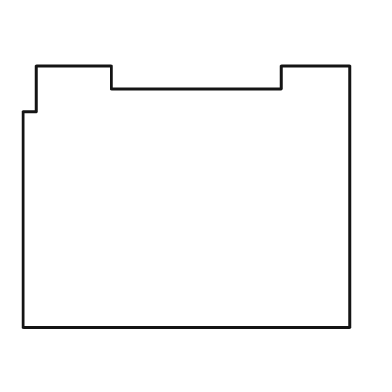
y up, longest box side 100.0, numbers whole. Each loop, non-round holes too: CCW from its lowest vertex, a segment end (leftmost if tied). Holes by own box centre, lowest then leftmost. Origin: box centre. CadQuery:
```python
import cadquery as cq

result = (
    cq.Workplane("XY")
    .moveTo(-50.0, -40.0)
    .lineTo(50.0, -40.0)
    .lineTo(50.0, 40.0)
    .lineTo(29.0, 40.0)
    .lineTo(29.0, 33.0)
    .lineTo(-23.0, 33.0)
    .lineTo(-23.0, 40.0)
    .lineTo(-46.0, 40.0)
    .lineTo(-46.0, 26.0)
    .lineTo(-50.0, 26.0)
    .close()
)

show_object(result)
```